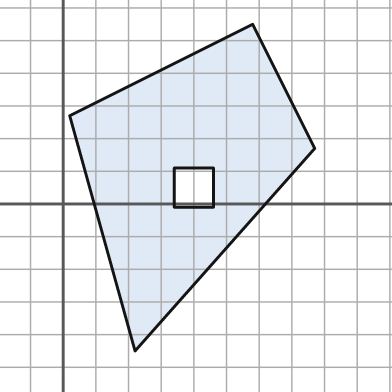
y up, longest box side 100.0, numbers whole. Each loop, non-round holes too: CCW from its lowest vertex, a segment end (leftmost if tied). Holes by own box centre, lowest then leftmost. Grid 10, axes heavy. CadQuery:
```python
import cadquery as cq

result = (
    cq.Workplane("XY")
    .moveTo(22.0, -45.0)
    .lineTo(77.0, 17.0)
    .lineTo(58.0, 55.0)
    .lineTo(2.0, 27.0)
    .close()
    .moveTo(34.0, -1.0)
    .lineTo(46.0, -1.0)
    .lineTo(46.0, 11.0)
    .lineTo(34.0, 11.0)
    .close()
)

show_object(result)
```